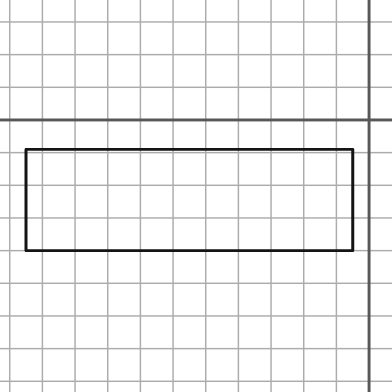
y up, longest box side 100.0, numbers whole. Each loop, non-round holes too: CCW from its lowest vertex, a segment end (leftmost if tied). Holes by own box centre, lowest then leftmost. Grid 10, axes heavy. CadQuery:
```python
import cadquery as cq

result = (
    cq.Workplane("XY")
    .moveTo(-105.0, -40.0)
    .lineTo(-5.0, -40.0)
    .lineTo(-5.0, -9.0)
    .lineTo(-105.0, -9.0)
    .close()
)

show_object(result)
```